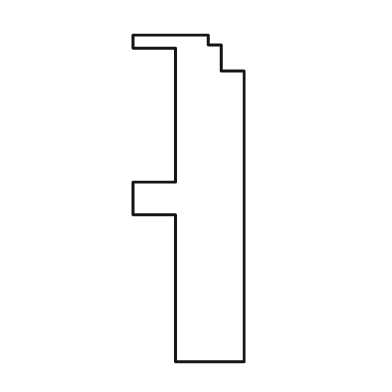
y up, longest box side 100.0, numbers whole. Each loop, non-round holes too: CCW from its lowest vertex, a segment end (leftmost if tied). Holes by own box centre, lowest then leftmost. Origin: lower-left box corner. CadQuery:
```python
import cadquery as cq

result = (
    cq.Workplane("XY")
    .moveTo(13.0, 0.0)
    .lineTo(34.0, 0.0)
    .lineTo(34.0, 89.0)
    .lineTo(27.0, 89.0)
    .lineTo(27.0, 97.0)
    .lineTo(23.0, 97.0)
    .lineTo(23.0, 100.0)
    .lineTo(0.0, 100.0)
    .lineTo(0.0, 96.0)
    .lineTo(13.0, 96.0)
    .lineTo(13.0, 55.0)
    .lineTo(0.0, 55.0)
    .lineTo(0.0, 45.0)
    .lineTo(13.0, 45.0)
    .close()
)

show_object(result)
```